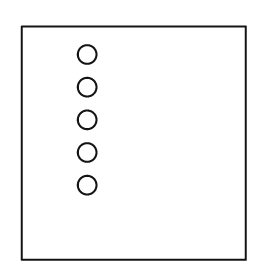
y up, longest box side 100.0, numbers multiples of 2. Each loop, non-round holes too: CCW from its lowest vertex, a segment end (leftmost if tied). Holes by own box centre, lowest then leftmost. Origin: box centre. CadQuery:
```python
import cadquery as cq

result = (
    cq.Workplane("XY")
    .moveTo(-48.0, -50.0)
    .lineTo(48.0, -50.0)
    .lineTo(48.0, 50.0)
    .lineTo(-48.0, 50.0)
    .close()
    .moveTo(-20.0, -18.0)
    .circle(4.0)
    .moveTo(-20.0, -4.0)
    .circle(4.0)
    .moveTo(-20.0, 10.0)
    .circle(4.0)
    .moveTo(-20.0, 24.0)
    .circle(4.0)
    .moveTo(-20.0, 38.0)
    .circle(4.0)
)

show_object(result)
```